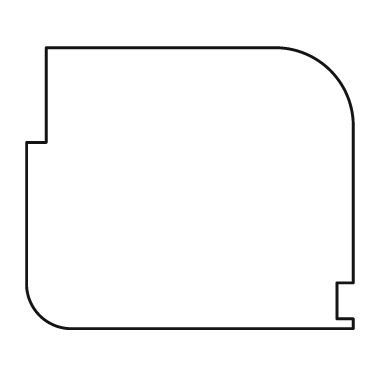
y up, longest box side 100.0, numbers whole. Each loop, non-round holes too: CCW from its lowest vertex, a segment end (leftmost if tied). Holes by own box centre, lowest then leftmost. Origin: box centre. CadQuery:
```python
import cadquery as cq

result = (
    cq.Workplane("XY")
    .moveTo(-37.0, -43.0)
    .lineTo(50.0, -43.0)
    .lineTo(50.0, -40.0)
    .lineTo(45.0, -40.0)
    .lineTo(45.0, -29.0)
    .lineTo(50.0, -29.0)
    .lineTo(50.0, 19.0)
    .threePointArc((43.0, 36.0), (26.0, 43.0))
    .lineTo(-44.0, 43.0)
    .lineTo(-44.0, 14.0)
    .lineTo(-50.0, 14.0)
    .lineTo(-50.0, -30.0)
    .threePointArc((-46.0, -39.0), (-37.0, -43.0))
    .close()
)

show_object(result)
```